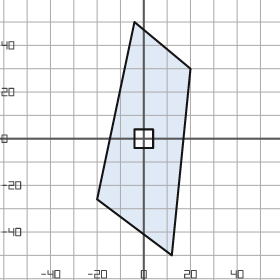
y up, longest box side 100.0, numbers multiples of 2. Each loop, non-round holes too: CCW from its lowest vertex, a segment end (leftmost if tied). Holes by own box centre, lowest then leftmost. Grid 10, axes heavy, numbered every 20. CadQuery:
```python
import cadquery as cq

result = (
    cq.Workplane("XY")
    .moveTo(12.0, -50.0)
    .lineTo(20.0, 30.0)
    .lineTo(-4.0, 50.0)
    .lineTo(-20.0, -26.0)
    .close()
    .moveTo(-4.0, -4.0)
    .lineTo(4.0, -4.0)
    .lineTo(4.0, 4.0)
    .lineTo(-4.0, 4.0)
    .close()
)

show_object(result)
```